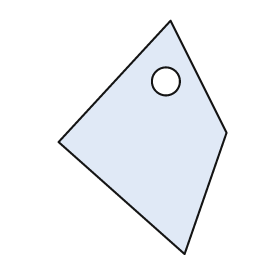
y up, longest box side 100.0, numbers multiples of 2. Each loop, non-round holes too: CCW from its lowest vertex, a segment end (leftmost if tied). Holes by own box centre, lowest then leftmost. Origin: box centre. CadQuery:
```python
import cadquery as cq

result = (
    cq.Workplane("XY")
    .moveTo(18.0, -50.0)
    .lineTo(36.0, 2.0)
    .lineTo(12.0, 50.0)
    .lineTo(-36.0, -2.0)
    .close()
    .moveTo(10.0, 24.0)
    .circle(6.0)
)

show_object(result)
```